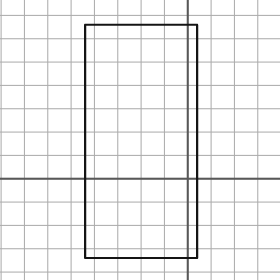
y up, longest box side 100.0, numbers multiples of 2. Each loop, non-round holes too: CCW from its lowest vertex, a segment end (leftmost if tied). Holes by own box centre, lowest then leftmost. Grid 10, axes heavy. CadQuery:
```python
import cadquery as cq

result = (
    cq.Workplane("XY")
    .moveTo(-44.0, -34.0)
    .lineTo(4.0, -34.0)
    .lineTo(4.0, 66.0)
    .lineTo(-44.0, 66.0)
    .close()
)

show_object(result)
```